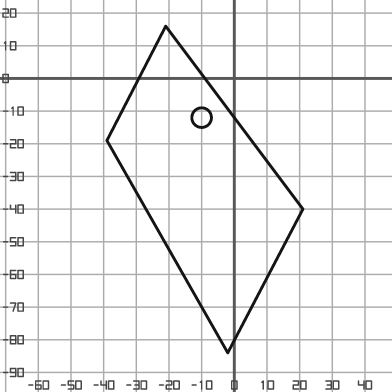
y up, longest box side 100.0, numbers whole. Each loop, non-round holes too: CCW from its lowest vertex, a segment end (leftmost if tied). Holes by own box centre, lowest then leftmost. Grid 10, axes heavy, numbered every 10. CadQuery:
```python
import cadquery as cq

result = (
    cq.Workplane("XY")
    .moveTo(-2.0, -84.0)
    .lineTo(21.0, -40.0)
    .lineTo(-21.0, 16.0)
    .lineTo(-39.0, -19.0)
    .close()
    .moveTo(-10.0, -12.0)
    .circle(3.0)
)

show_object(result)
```